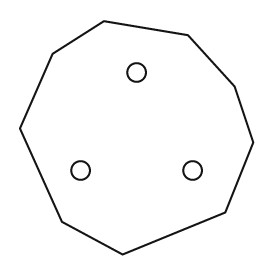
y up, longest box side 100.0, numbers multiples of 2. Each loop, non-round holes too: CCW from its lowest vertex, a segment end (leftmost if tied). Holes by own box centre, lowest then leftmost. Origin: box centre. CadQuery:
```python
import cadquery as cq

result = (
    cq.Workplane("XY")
    .moveTo(-6.0, -50.0)
    .lineTo(38.0, -32.0)
    .lineTo(50.0, -2.0)
    .lineTo(42.0, 22.0)
    .lineTo(22.0, 44.0)
    .lineTo(-14.0, 50.0)
    .lineTo(-36.0, 36.0)
    .lineTo(-50.0, 4.0)
    .lineTo(-32.0, -36.0)
    .close()
    .moveTo(-24.0, -14.0)
    .circle(4.0)
    .moveTo(24.0, -14.0)
    .circle(4.0)
    .moveTo(0.0, 28.0)
    .circle(4.0)
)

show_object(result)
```